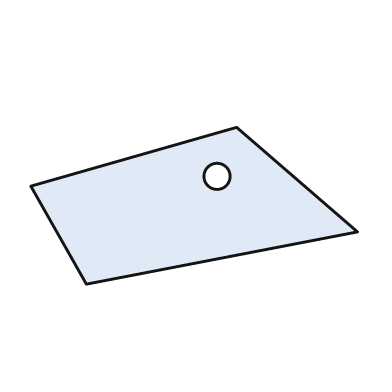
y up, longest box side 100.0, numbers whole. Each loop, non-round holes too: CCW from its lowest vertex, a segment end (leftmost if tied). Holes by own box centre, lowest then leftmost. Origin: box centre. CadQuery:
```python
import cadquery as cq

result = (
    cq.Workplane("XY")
    .moveTo(-33.0, -24.0)
    .lineTo(50.0, -8.0)
    .lineTo(13.0, 24.0)
    .lineTo(-50.0, 6.0)
    .close()
    .moveTo(7.0, 9.0)
    .circle(4.0)
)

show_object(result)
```